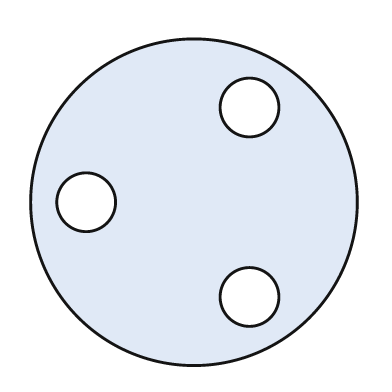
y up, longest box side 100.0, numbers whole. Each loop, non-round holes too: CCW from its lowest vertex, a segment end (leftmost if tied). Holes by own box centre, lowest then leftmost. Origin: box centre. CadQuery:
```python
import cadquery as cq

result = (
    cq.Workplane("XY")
    .moveTo(0.0, 0.0)
    .circle(50.0)
    .moveTo(17.0, -29.0)
    .circle(9.0)
    .moveTo(-33.0, 0.0)
    .circle(9.0)
    .moveTo(17.0, 29.0)
    .circle(9.0)
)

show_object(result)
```